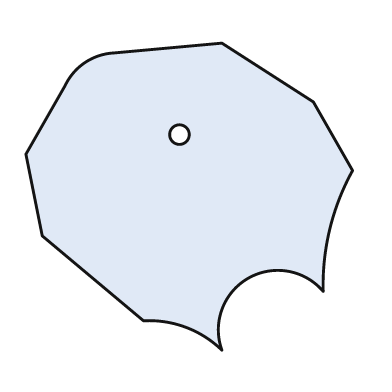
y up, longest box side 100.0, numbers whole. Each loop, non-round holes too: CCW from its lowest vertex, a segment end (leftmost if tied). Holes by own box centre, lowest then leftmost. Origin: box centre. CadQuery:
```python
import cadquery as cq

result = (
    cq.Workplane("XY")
    .moveTo(10.0, -47.0)
    .threePointArc((18.0, -25.0), (41.0, -29.0))
    .threePointArc((43.0, -10.0), (50.0, 8.0))
    .lineTo(38.0, 29.0)
    .lineTo(10.0, 47.0)
    .lineTo(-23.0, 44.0)
    .threePointArc((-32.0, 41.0), (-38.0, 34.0))
    .lineTo(-50.0, 13.0)
    .lineTo(-45.0, -12.0)
    .lineTo(-14.0, -38.0)
    .threePointArc((-1.0, -40.0), (10.0, -47.0))
    .close()
    .moveTo(-3.0, 19.0)
    .circle(3.0)
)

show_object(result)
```